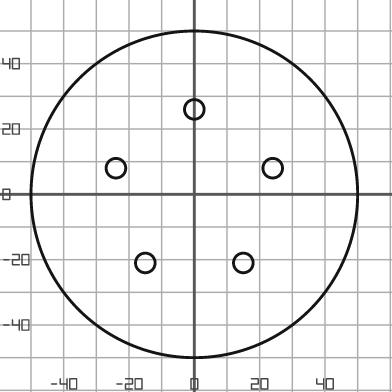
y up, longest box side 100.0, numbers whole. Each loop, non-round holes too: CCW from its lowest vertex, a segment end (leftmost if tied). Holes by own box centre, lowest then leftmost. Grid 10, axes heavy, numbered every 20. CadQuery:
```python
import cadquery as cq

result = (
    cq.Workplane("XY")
    .moveTo(0.0, 0.0)
    .circle(50.0)
    .moveTo(-15.0, -21.0)
    .circle(3.0)
    .moveTo(15.0, -21.0)
    .circle(3.0)
    .moveTo(-24.0, 8.0)
    .circle(3.0)
    .moveTo(24.0, 8.0)
    .circle(3.0)
    .moveTo(0.0, 26.0)
    .circle(3.0)
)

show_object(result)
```